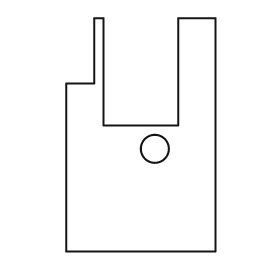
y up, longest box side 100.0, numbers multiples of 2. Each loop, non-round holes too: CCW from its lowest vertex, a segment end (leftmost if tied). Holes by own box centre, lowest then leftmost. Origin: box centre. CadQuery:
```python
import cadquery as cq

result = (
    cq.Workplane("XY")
    .moveTo(-32.0, -50.0)
    .lineTo(32.0, -50.0)
    .lineTo(32.0, 50.0)
    .lineTo(16.0, 50.0)
    .lineTo(16.0, 4.0)
    .lineTo(-16.0, 4.0)
    .lineTo(-16.0, 50.0)
    .lineTo(-20.0, 50.0)
    .lineTo(-20.0, 22.0)
    .lineTo(-32.0, 22.0)
    .close()
    .moveTo(6.0, -6.0)
    .circle(6.0)
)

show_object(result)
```